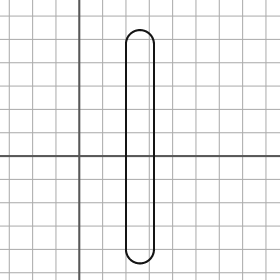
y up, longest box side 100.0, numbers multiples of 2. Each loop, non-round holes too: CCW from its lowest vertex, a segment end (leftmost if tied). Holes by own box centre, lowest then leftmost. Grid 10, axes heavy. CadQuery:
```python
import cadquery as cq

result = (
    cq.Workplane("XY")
    .moveTo(20.0, -40.0)
    .threePointArc((26.0, -46.0), (32.0, -40.0))
    .lineTo(32.0, 48.0)
    .threePointArc((26.0, 54.0), (20.0, 48.0))
    .close()
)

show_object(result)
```